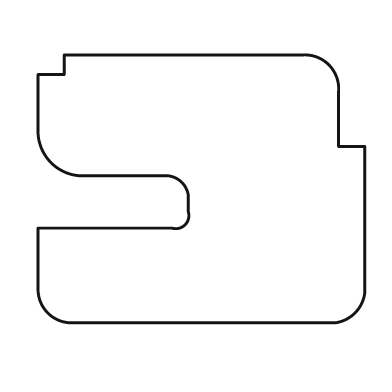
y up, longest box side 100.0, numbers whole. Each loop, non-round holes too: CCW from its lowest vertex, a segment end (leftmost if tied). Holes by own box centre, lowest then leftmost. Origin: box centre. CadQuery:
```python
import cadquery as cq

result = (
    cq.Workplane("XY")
    .moveTo(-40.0, -41.0)
    .lineTo(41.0, -41.0)
    .threePointArc((47.0, -38.0), (50.0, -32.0))
    .lineTo(50.0, 13.0)
    .lineTo(42.0, 13.0)
    .lineTo(42.0, 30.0)
    .threePointArc((39.0, 38.0), (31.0, 41.0))
    .lineTo(-42.0, 41.0)
    .lineTo(-42.0, 35.0)
    .lineTo(-50.0, 35.0)
    .lineTo(-50.0, 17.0)
    .threePointArc((-46.0, 8.0), (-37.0, 4.0))
    .lineTo(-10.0, 4.0)
    .threePointArc((-6.0, 2.0), (-4.0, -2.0))
    .lineTo(-4.0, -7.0)
    .threePointArc((-5.0, -11.0), (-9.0, -12.0))
    .lineTo(-50.0, -12.0)
    .lineTo(-50.0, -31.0)
    .threePointArc((-47.0, -38.0), (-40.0, -41.0))
    .close()
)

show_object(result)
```